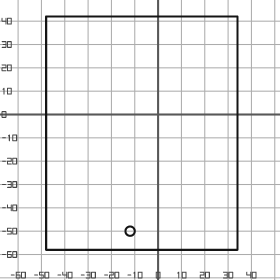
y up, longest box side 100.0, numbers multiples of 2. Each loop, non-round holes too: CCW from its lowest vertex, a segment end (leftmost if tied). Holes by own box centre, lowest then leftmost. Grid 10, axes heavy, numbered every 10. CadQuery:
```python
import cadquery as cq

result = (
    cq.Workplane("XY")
    .moveTo(-48.0, -58.0)
    .lineTo(34.0, -58.0)
    .lineTo(34.0, 42.0)
    .lineTo(-48.0, 42.0)
    .close()
    .moveTo(-12.0, -50.0)
    .circle(2.0)
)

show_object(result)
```